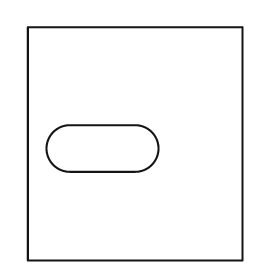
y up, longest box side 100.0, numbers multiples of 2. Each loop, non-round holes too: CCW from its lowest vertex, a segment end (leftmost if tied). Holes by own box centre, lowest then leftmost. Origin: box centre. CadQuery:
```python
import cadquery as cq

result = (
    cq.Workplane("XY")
    .moveTo(-46.0, -50.0)
    .lineTo(46.0, -50.0)
    .lineTo(46.0, 50.0)
    .lineTo(-46.0, 50.0)
    .close()
    .moveTo(-28.0, -12.0)
    .lineTo(0.0, -12.0)
    .threePointArc((10.0, -2.0), (0.0, 8.0))
    .lineTo(-28.0, 8.0)
    .threePointArc((-38.0, -2.0), (-28.0, -12.0))
    .close()
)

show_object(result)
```